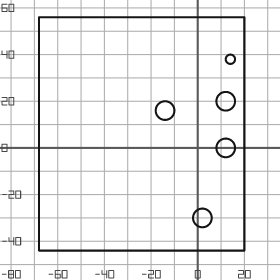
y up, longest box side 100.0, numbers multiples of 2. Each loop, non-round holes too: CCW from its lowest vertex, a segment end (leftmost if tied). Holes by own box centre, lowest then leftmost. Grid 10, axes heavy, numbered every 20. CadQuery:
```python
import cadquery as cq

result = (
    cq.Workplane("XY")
    .moveTo(-68.0, -44.0)
    .lineTo(20.0, -44.0)
    .lineTo(20.0, 56.0)
    .lineTo(-68.0, 56.0)
    .close()
    .moveTo(2.0, -30.0)
    .circle(4.0)
    .moveTo(12.0, 0.0)
    .circle(4.0)
    .moveTo(-14.0, 16.0)
    .circle(4.0)
    .moveTo(12.0, 20.0)
    .circle(4.0)
    .moveTo(14.0, 38.0)
    .circle(2.0)
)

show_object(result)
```